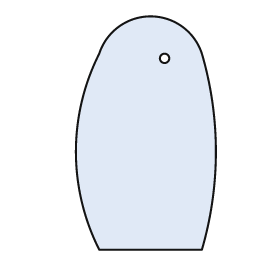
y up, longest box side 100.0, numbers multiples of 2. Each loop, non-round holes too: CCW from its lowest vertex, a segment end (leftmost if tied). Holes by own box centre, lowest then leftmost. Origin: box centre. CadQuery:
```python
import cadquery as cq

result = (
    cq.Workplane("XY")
    .moveTo(-20.0, -50.0)
    .lineTo(24.0, -50.0)
    .threePointArc((30.0, -8.0), (24.0, 34.0))
    .threePointArc((2.0, 50.0), (-20.0, 34.0))
    .threePointArc((-30.0, -8.0), (-20.0, -50.0))
    .close()
    .moveTo(8.0, 32.0)
    .circle(2.0)
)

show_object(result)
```